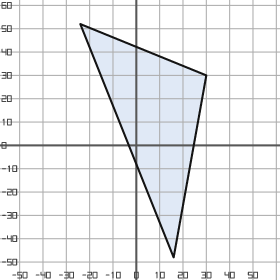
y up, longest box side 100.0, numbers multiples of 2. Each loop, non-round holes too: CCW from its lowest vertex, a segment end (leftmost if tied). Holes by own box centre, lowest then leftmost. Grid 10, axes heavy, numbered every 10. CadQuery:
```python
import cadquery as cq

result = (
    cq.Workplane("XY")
    .moveTo(16.0, -48.0)
    .lineTo(30.0, 30.0)
    .lineTo(-24.0, 52.0)
    .close()
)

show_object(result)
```